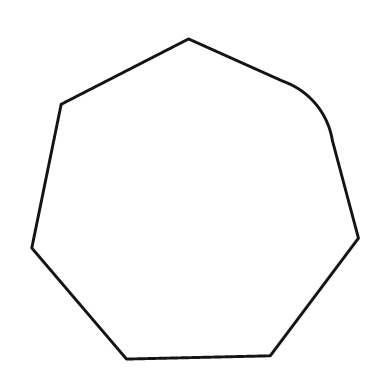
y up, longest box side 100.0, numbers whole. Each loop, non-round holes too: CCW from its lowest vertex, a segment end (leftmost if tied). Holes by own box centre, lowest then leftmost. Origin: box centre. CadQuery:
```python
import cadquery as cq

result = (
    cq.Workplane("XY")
    .moveTo(-21.0, -49.0)
    .lineTo(23.0, -48.0)
    .lineTo(50.0, -12.0)
    .lineTo(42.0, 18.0)
    .threePointArc((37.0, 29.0), (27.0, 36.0))
    .lineTo(-2.0, 49.0)
    .lineTo(-41.0, 29.0)
    .lineTo(-50.0, -15.0)
    .close()
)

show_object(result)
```